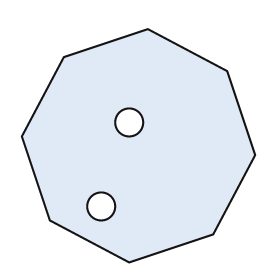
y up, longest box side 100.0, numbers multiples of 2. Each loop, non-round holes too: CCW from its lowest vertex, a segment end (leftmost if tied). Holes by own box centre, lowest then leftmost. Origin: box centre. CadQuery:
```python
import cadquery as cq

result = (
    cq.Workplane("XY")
    .moveTo(-4.0, -50.0)
    .lineTo(32.0, -38.0)
    .lineTo(50.0, -4.0)
    .lineTo(38.0, 32.0)
    .lineTo(4.0, 50.0)
    .lineTo(-32.0, 38.0)
    .lineTo(-50.0, 4.0)
    .lineTo(-38.0, -32.0)
    .close()
    .moveTo(-16.0, -26.0)
    .circle(6.0)
    .moveTo(-4.0, 10.0)
    .circle(6.0)
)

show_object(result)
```